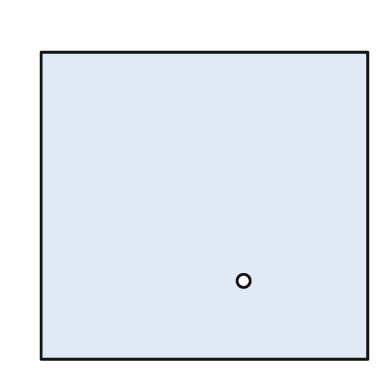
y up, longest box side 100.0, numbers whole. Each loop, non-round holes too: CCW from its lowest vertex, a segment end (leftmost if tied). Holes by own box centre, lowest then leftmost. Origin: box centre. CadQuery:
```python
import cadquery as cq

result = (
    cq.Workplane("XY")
    .moveTo(-50.0, -47.0)
    .lineTo(50.0, -47.0)
    .lineTo(50.0, 47.0)
    .lineTo(-50.0, 47.0)
    .close()
    .moveTo(12.0, -23.0)
    .circle(2.0)
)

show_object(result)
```